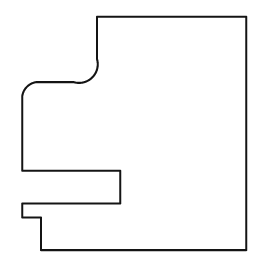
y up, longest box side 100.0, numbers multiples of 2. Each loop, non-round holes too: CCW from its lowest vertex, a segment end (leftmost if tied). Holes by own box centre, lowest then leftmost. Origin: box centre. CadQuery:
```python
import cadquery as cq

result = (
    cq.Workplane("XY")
    .moveTo(-40.0, -50.0)
    .lineTo(48.0, -50.0)
    .lineTo(48.0, 50.0)
    .lineTo(-16.0, 50.0)
    .lineTo(-16.0, 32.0)
    .threePointArc((-18.0, 24.0), (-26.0, 22.0))
    .lineTo(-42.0, 22.0)
    .threePointArc((-46.0, 20.0), (-48.0, 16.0))
    .lineTo(-48.0, -16.0)
    .lineTo(-6.0, -16.0)
    .lineTo(-6.0, -30.0)
    .lineTo(-48.0, -30.0)
    .lineTo(-48.0, -36.0)
    .lineTo(-40.0, -36.0)
    .close()
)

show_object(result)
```